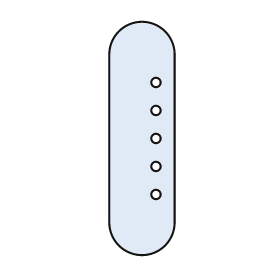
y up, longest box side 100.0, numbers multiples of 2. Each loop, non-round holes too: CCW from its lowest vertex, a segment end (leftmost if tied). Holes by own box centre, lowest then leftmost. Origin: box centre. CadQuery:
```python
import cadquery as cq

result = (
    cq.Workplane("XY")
    .moveTo(-14.0, -36.0)
    .threePointArc((0.0, -50.0), (14.0, -36.0))
    .lineTo(14.0, 36.0)
    .threePointArc((0.0, 50.0), (-14.0, 36.0))
    .close()
    .moveTo(6.0, -24.0)
    .circle(2.0)
    .moveTo(6.0, -12.0)
    .circle(2.0)
    .moveTo(6.0, 0.0)
    .circle(2.0)
    .moveTo(6.0, 12.0)
    .circle(2.0)
    .moveTo(6.0, 24.0)
    .circle(2.0)
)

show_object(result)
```